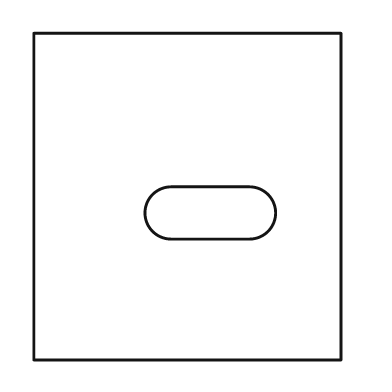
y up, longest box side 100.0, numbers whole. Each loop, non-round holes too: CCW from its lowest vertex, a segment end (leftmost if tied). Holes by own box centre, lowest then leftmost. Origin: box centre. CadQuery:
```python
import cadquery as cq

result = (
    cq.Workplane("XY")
    .moveTo(-47.0, -50.0)
    .lineTo(47.0, -50.0)
    .lineTo(47.0, 50.0)
    .lineTo(-47.0, 50.0)
    .close()
    .moveTo(-5.0, -13.0)
    .lineTo(19.0, -13.0)
    .threePointArc((27.0, -5.0), (19.0, 3.0))
    .lineTo(-5.0, 3.0)
    .threePointArc((-13.0, -5.0), (-5.0, -13.0))
    .close()
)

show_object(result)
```